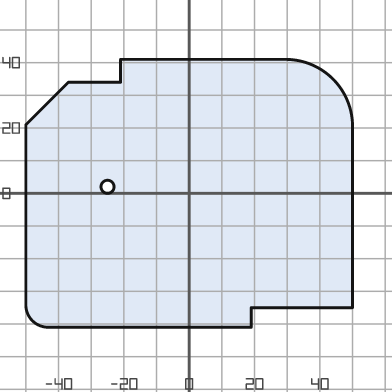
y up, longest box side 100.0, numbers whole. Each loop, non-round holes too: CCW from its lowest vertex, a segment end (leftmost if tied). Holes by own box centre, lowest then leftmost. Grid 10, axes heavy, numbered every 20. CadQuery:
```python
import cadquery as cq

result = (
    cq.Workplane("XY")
    .moveTo(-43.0, -41.0)
    .lineTo(19.0, -41.0)
    .lineTo(19.0, -35.0)
    .lineTo(50.0, -35.0)
    .lineTo(50.0, 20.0)
    .threePointArc((44.0, 35.0), (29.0, 41.0))
    .lineTo(-21.0, 41.0)
    .lineTo(-21.0, 34.0)
    .lineTo(-37.0, 34.0)
    .lineTo(-50.0, 21.0)
    .lineTo(-50.0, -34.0)
    .threePointArc((-48.0, -39.0), (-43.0, -41.0))
    .close()
    .moveTo(-25.0, 2.0)
    .circle(2.0)
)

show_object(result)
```